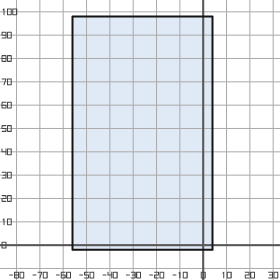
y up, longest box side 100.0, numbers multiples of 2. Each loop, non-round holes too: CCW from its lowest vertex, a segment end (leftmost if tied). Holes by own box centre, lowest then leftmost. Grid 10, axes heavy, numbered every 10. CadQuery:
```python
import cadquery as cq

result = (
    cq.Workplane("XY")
    .moveTo(-56.0, -2.0)
    .lineTo(4.0, -2.0)
    .lineTo(4.0, 98.0)
    .lineTo(-56.0, 98.0)
    .close()
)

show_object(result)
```